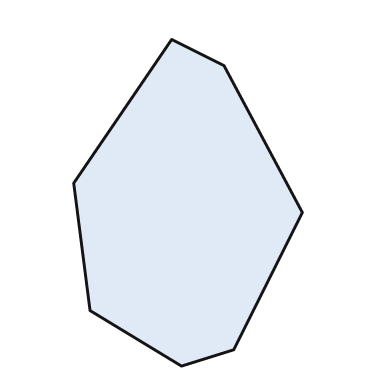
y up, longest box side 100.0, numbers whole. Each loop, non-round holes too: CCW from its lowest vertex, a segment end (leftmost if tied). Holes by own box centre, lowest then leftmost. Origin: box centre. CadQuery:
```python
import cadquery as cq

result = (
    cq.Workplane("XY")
    .moveTo(-2.0, -50.0)
    .lineTo(14.0, -45.0)
    .lineTo(35.0, -3.0)
    .lineTo(11.0, 42.0)
    .lineTo(-5.0, 50.0)
    .lineTo(-35.0, 6.0)
    .lineTo(-30.0, -33.0)
    .close()
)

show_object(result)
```